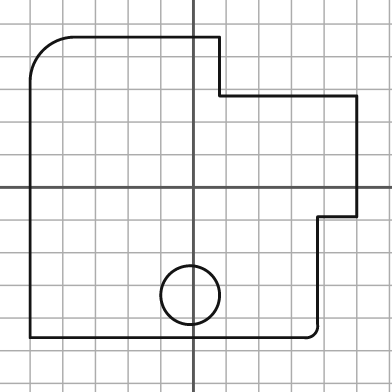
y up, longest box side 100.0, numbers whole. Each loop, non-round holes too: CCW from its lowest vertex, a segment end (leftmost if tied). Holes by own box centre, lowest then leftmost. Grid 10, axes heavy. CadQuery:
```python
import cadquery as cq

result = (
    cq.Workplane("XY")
    .moveTo(-50.0, -46.0)
    .lineTo(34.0, -46.0)
    .threePointArc((37.0, -45.0), (38.0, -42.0))
    .lineTo(38.0, -9.0)
    .lineTo(50.0, -9.0)
    .lineTo(50.0, 28.0)
    .lineTo(8.0, 28.0)
    .lineTo(8.0, 46.0)
    .lineTo(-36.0, 46.0)
    .threePointArc((-46.0, 42.0), (-50.0, 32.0))
    .close()
    .moveTo(-1.0, -33.0)
    .circle(9.0)
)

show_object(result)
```